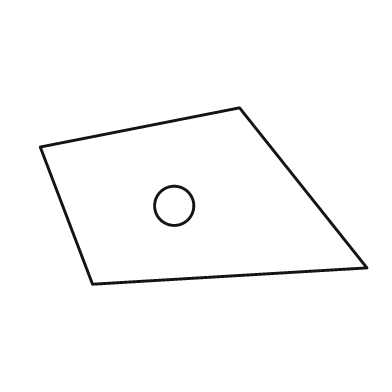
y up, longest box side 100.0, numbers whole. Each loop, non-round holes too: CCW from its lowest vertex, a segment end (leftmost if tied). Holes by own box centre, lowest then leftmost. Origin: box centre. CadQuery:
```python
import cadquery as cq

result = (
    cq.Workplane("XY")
    .moveTo(-34.0, -27.0)
    .lineTo(50.0, -22.0)
    .lineTo(11.0, 27.0)
    .lineTo(-50.0, 15.0)
    .close()
    .moveTo(-9.0, -3.0)
    .circle(6.0)
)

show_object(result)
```